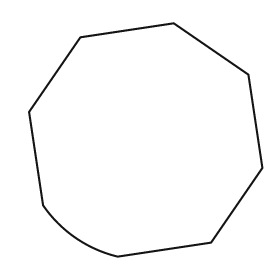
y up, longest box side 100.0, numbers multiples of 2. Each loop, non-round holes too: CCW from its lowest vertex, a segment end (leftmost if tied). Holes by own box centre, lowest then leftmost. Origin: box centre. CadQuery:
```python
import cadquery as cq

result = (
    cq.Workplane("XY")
    .moveTo(-12.0, -50.0)
    .lineTo(28.0, -44.0)
    .lineTo(50.0, -12.0)
    .lineTo(44.0, 28.0)
    .lineTo(12.0, 50.0)
    .lineTo(-28.0, 44.0)
    .lineTo(-50.0, 12.0)
    .lineTo(-44.0, -28.0)
    .threePointArc((-30.0, -42.0), (-12.0, -50.0))
    .close()
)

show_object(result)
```